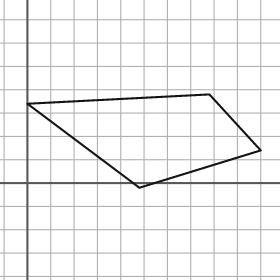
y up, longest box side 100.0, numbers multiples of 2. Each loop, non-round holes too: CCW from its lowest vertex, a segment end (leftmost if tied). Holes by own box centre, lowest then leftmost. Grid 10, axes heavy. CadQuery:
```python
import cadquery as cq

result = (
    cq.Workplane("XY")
    .moveTo(48.0, -2.0)
    .lineTo(100.0, 14.0)
    .lineTo(78.0, 38.0)
    .lineTo(0.0, 34.0)
    .close()
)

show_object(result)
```